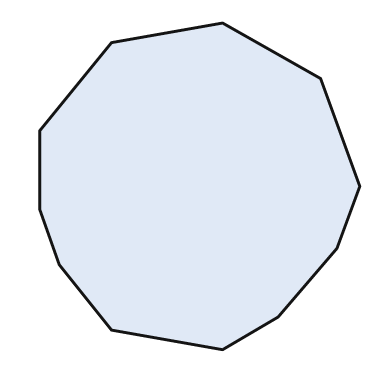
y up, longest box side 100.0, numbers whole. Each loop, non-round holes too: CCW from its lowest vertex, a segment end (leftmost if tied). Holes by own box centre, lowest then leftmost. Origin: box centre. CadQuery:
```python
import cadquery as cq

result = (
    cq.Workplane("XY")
    .moveTo(7.0, -50.0)
    .lineTo(24.0, -40.0)
    .lineTo(42.0, -19.0)
    .lineTo(49.0, 0.0)
    .lineTo(37.0, 33.0)
    .lineTo(7.0, 50.0)
    .lineTo(-27.0, 44.0)
    .lineTo(-49.0, 17.0)
    .lineTo(-49.0, -7.0)
    .lineTo(-43.0, -24.0)
    .lineTo(-27.0, -44.0)
    .close()
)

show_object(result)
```